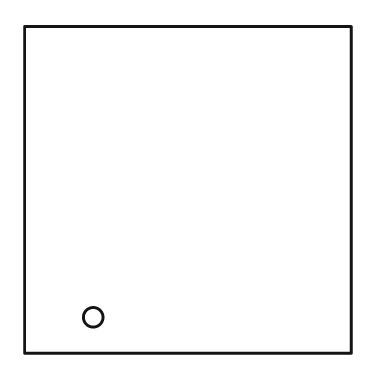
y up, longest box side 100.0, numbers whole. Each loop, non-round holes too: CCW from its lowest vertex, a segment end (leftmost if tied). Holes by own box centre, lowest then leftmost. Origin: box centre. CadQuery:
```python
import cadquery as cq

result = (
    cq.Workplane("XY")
    .moveTo(-50.0, -50.0)
    .lineTo(50.0, -50.0)
    .lineTo(50.0, 50.0)
    .lineTo(-50.0, 50.0)
    .close()
    .moveTo(-29.0, -39.0)
    .circle(3.0)
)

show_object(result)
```